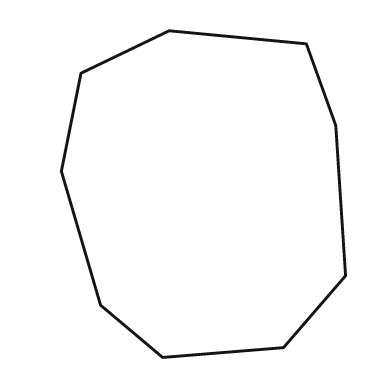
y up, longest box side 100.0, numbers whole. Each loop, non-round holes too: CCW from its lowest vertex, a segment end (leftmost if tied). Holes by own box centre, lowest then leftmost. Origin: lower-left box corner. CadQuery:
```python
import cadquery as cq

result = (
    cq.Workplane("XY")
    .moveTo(31.0, 0.0)
    .lineTo(68.0, 3.0)
    .lineTo(87.0, 25.0)
    .lineTo(84.0, 71.0)
    .lineTo(75.0, 96.0)
    .lineTo(33.0, 100.0)
    .lineTo(6.0, 87.0)
    .lineTo(0.0, 57.0)
    .lineTo(12.0, 16.0)
    .close()
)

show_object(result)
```